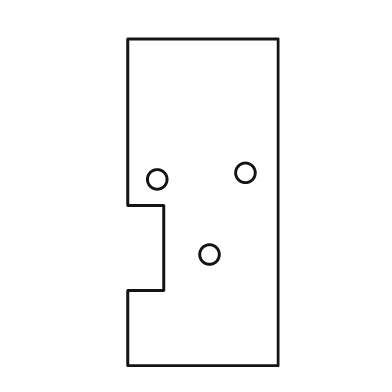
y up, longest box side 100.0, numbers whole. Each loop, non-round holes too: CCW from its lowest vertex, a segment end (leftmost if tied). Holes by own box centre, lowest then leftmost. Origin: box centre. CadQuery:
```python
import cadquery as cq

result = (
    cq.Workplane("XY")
    .moveTo(-23.0, -50.0)
    .lineTo(23.0, -50.0)
    .lineTo(23.0, 50.0)
    .lineTo(-23.0, 50.0)
    .lineTo(-23.0, -1.0)
    .lineTo(-12.0, -1.0)
    .lineTo(-12.0, -27.0)
    .lineTo(-23.0, -27.0)
    .close()
    .moveTo(2.0, -16.0)
    .circle(3.0)
    .moveTo(-14.0, 7.0)
    .circle(3.0)
    .moveTo(13.0, 9.0)
    .circle(3.0)
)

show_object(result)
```